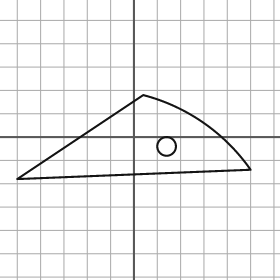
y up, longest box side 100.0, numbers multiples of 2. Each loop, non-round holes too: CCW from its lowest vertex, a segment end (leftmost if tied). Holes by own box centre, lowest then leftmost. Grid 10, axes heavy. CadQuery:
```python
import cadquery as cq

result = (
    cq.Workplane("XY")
    .moveTo(-50.0, -18.0)
    .lineTo(50.0, -14.0)
    .threePointArc((30.0, 6.0), (4.0, 18.0))
    .close()
    .moveTo(14.0, -4.0)
    .circle(4.0)
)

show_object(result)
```